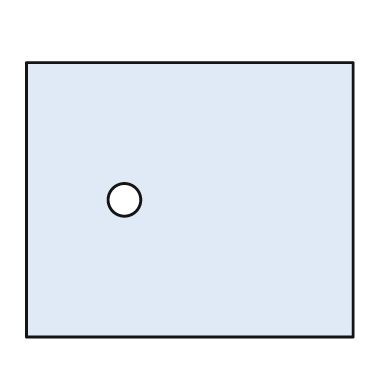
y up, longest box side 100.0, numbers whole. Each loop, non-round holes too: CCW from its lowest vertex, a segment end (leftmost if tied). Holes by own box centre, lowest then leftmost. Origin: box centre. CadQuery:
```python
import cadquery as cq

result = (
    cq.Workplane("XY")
    .moveTo(-50.0, -42.0)
    .lineTo(50.0, -42.0)
    .lineTo(50.0, 42.0)
    .lineTo(-50.0, 42.0)
    .close()
    .moveTo(-20.0, 0.0)
    .circle(5.0)
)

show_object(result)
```